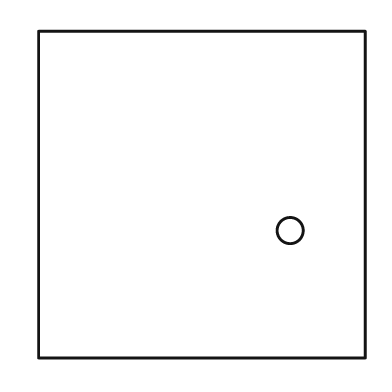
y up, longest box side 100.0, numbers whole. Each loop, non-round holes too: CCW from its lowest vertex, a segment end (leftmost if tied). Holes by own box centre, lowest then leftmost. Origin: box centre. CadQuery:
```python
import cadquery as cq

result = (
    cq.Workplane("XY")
    .moveTo(-50.0, -50.0)
    .lineTo(50.0, -50.0)
    .lineTo(50.0, 50.0)
    .lineTo(-50.0, 50.0)
    .close()
    .moveTo(27.0, -11.0)
    .circle(4.0)
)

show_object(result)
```